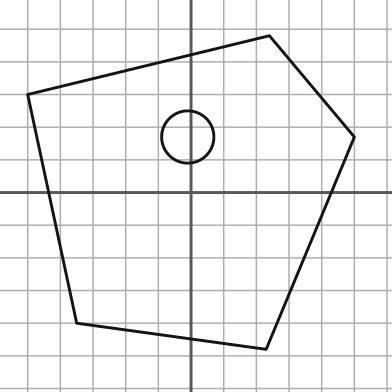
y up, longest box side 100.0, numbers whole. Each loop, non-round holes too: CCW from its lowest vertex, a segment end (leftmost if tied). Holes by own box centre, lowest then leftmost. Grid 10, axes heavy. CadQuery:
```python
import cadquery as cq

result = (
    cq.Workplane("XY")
    .moveTo(23.0, -48.0)
    .lineTo(50.0, 17.0)
    .lineTo(24.0, 48.0)
    .lineTo(-50.0, 30.0)
    .lineTo(-35.0, -40.0)
    .close()
    .moveTo(-1.0, 17.0)
    .circle(8.0)
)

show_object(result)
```